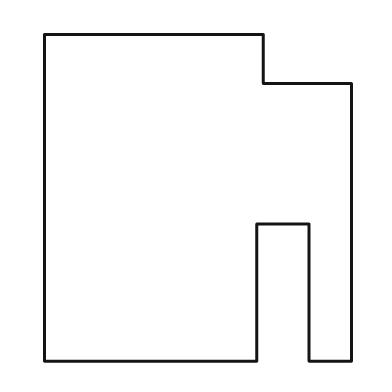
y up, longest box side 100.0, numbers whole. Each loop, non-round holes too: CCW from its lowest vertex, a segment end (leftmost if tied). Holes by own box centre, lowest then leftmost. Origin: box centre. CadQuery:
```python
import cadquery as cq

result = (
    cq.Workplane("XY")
    .moveTo(-47.0, -50.0)
    .lineTo(18.0, -50.0)
    .lineTo(18.0, -8.0)
    .lineTo(34.0, -8.0)
    .lineTo(34.0, -50.0)
    .lineTo(47.0, -50.0)
    .lineTo(47.0, 35.0)
    .lineTo(20.0, 35.0)
    .lineTo(20.0, 50.0)
    .lineTo(-47.0, 50.0)
    .close()
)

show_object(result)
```